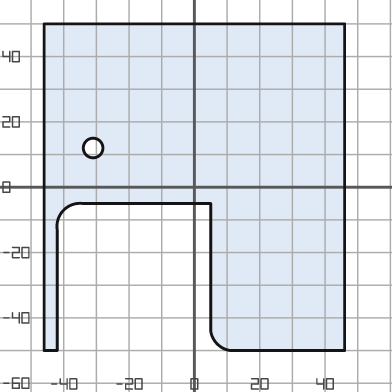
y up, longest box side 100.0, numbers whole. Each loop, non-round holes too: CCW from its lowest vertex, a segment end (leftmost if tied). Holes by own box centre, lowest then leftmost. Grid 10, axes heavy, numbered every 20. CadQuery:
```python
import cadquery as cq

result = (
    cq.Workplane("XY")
    .moveTo(-46.0, -50.0)
    .lineTo(-42.0, -50.0)
    .lineTo(-42.0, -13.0)
    .threePointArc((-40.0, -7.0), (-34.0, -5.0))
    .lineTo(5.0, -5.0)
    .lineTo(5.0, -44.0)
    .threePointArc((7.0, -48.0), (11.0, -50.0))
    .lineTo(46.0, -50.0)
    .lineTo(46.0, 50.0)
    .lineTo(-46.0, 50.0)
    .close()
    .moveTo(-31.0, 12.0)
    .circle(3.0)
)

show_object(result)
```